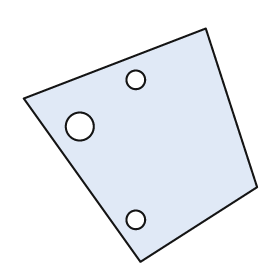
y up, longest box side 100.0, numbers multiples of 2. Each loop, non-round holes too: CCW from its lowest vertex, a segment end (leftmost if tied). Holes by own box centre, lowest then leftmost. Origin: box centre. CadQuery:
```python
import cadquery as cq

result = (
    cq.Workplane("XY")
    .moveTo(0.0, -50.0)
    .lineTo(50.0, -18.0)
    .lineTo(28.0, 50.0)
    .lineTo(-50.0, 20.0)
    .close()
    .moveTo(-2.0, -32.0)
    .circle(4.0)
    .moveTo(-26.0, 8.0)
    .circle(6.0)
    .moveTo(-2.0, 28.0)
    .circle(4.0)
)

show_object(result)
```